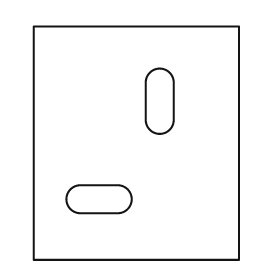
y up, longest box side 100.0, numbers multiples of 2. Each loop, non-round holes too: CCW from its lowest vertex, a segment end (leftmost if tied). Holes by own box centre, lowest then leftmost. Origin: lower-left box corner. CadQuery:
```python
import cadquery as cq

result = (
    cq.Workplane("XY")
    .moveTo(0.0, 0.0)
    .lineTo(88.0, 0.0)
    .lineTo(88.0, 100.0)
    .lineTo(0.0, 100.0)
    .close()
    .moveTo(20.0, 20.0)
    .lineTo(36.0, 20.0)
    .threePointArc((42.0, 26.0), (36.0, 32.0))
    .lineTo(20.0, 32.0)
    .threePointArc((14.0, 26.0), (20.0, 20.0))
    .close()
    .moveTo(48.0, 60.0)
    .threePointArc((54.0, 54.0), (60.0, 60.0))
    .lineTo(60.0, 76.0)
    .threePointArc((54.0, 82.0), (48.0, 76.0))
    .close()
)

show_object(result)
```